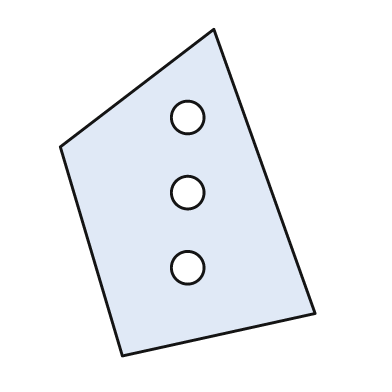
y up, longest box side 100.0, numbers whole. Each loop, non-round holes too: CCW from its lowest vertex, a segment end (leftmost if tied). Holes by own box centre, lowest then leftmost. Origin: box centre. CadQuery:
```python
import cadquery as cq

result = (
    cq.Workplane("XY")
    .moveTo(-20.0, -50.0)
    .lineTo(39.0, -37.0)
    .lineTo(8.0, 50.0)
    .lineTo(-39.0, 14.0)
    .close()
    .moveTo(0.0, -23.0)
    .circle(5.0)
    .moveTo(0.0, 0.0)
    .circle(5.0)
    .moveTo(0.0, 23.0)
    .circle(5.0)
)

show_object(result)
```